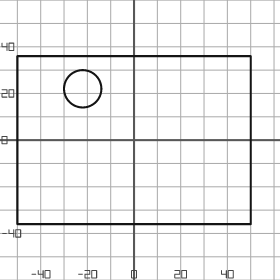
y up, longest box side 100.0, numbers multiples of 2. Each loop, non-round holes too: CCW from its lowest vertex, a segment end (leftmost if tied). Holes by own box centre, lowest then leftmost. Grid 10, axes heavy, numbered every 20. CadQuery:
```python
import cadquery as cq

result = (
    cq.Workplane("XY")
    .moveTo(-50.0, -36.0)
    .lineTo(50.0, -36.0)
    .lineTo(50.0, 36.0)
    .lineTo(-50.0, 36.0)
    .close()
    .moveTo(-22.0, 22.0)
    .circle(8.0)
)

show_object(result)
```